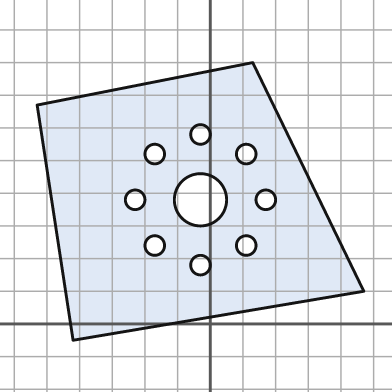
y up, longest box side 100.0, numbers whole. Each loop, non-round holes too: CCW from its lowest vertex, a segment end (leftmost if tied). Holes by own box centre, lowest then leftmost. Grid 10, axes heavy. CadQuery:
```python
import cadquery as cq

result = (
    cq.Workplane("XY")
    .moveTo(-42.0, -5.0)
    .lineTo(47.0, 10.0)
    .lineTo(13.0, 80.0)
    .lineTo(-53.0, 67.0)
    .close()
    .moveTo(-3.0, 18.0)
    .circle(3.0)
    .moveTo(-17.0, 24.0)
    .circle(3.0)
    .moveTo(11.0, 24.0)
    .circle(3.0)
    .moveTo(-23.0, 38.0)
    .circle(3.0)
    .moveTo(-3.0, 38.0)
    .circle(8.0)
    .moveTo(17.0, 38.0)
    .circle(3.0)
    .moveTo(-17.0, 52.0)
    .circle(3.0)
    .moveTo(11.0, 52.0)
    .circle(3.0)
    .moveTo(-3.0, 58.0)
    .circle(3.0)
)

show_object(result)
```